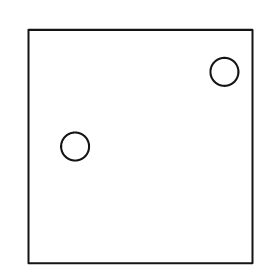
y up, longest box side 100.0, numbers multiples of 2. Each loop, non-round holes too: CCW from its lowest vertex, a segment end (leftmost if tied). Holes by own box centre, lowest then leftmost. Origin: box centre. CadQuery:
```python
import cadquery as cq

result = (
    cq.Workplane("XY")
    .moveTo(-48.0, -50.0)
    .lineTo(48.0, -50.0)
    .lineTo(48.0, 50.0)
    .lineTo(-48.0, 50.0)
    .close()
    .moveTo(-28.0, 0.0)
    .circle(6.0)
    .moveTo(36.0, 32.0)
    .circle(6.0)
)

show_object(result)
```